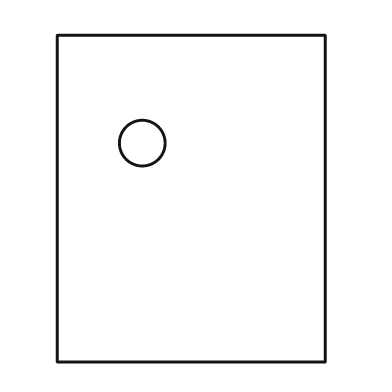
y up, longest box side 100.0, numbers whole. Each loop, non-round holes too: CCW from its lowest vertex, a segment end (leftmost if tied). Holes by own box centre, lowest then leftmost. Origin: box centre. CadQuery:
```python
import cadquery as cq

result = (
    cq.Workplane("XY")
    .moveTo(-41.0, -50.0)
    .lineTo(41.0, -50.0)
    .lineTo(41.0, 50.0)
    .lineTo(-41.0, 50.0)
    .close()
    .moveTo(-15.0, 17.0)
    .circle(7.0)
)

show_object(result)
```